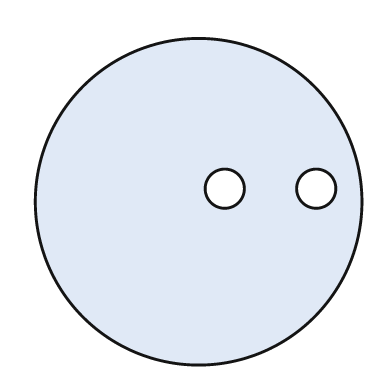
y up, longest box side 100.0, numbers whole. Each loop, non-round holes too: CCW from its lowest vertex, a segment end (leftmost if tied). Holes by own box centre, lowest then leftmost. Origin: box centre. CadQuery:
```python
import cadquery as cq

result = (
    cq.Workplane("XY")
    .moveTo(0.0, 0.0)
    .circle(50.0)
    .moveTo(8.0, 4.0)
    .circle(6.0)
    .moveTo(36.0, 4.0)
    .circle(6.0)
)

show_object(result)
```